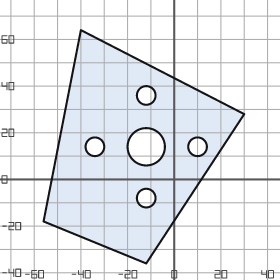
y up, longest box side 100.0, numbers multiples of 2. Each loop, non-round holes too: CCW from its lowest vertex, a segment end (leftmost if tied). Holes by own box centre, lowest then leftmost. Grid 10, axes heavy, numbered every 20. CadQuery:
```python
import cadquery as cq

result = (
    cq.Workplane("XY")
    .moveTo(-12.0, -36.0)
    .lineTo(30.0, 28.0)
    .lineTo(-40.0, 64.0)
    .lineTo(-56.0, -18.0)
    .close()
    .moveTo(-12.0, -8.0)
    .circle(4.0)
    .moveTo(-34.0, 14.0)
    .circle(4.0)
    .moveTo(-12.0, 14.0)
    .circle(8.0)
    .moveTo(10.0, 14.0)
    .circle(4.0)
    .moveTo(-12.0, 36.0)
    .circle(4.0)
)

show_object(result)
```